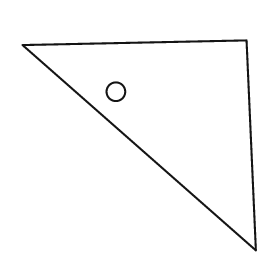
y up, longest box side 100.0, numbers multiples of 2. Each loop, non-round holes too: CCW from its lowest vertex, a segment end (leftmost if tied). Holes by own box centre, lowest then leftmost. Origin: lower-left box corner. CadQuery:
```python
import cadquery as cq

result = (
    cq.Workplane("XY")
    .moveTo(100.0, 0.0)
    .lineTo(96.0, 90.0)
    .lineTo(0.0, 88.0)
    .close()
    .moveTo(40.0, 68.0)
    .circle(4.0)
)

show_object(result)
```